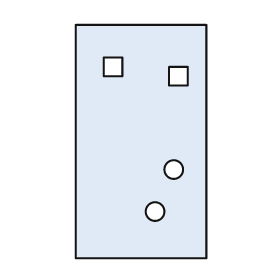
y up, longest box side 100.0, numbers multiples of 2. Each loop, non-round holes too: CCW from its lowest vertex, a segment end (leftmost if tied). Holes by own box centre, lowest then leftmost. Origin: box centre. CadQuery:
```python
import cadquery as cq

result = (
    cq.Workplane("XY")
    .moveTo(-28.0, -50.0)
    .lineTo(28.0, -50.0)
    .lineTo(28.0, 50.0)
    .lineTo(-28.0, 50.0)
    .close()
    .moveTo(6.0, -30.0)
    .circle(4.0)
    .moveTo(14.0, -12.0)
    .circle(4.0)
    .moveTo(12.0, 24.0)
    .lineTo(20.0, 24.0)
    .lineTo(20.0, 32.0)
    .lineTo(12.0, 32.0)
    .close()
    .moveTo(-16.0, 28.0)
    .lineTo(-8.0, 28.0)
    .lineTo(-8.0, 36.0)
    .lineTo(-16.0, 36.0)
    .close()
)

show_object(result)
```